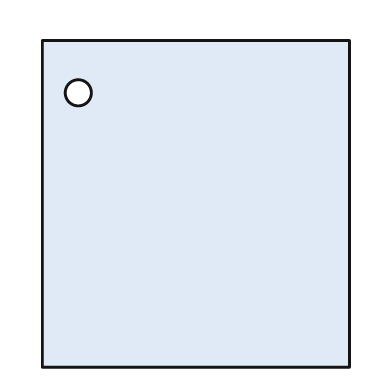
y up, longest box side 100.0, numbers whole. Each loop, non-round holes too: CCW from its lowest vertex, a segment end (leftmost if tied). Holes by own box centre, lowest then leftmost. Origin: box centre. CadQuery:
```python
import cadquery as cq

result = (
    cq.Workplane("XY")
    .moveTo(-47.0, -50.0)
    .lineTo(47.0, -50.0)
    .lineTo(47.0, 50.0)
    .lineTo(-47.0, 50.0)
    .close()
    .moveTo(-36.0, 34.0)
    .circle(4.0)
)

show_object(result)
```